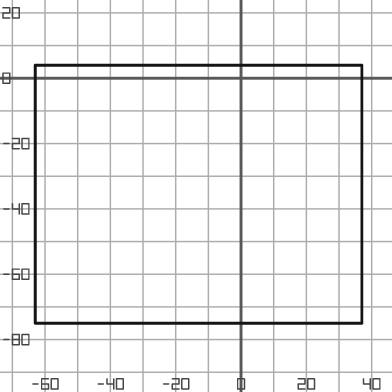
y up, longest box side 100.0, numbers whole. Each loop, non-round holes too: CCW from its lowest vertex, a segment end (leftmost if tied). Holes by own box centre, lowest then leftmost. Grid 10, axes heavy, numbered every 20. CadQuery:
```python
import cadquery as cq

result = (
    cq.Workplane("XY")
    .moveTo(-63.0, -75.0)
    .lineTo(37.0, -75.0)
    .lineTo(37.0, 4.0)
    .lineTo(-63.0, 4.0)
    .close()
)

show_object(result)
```